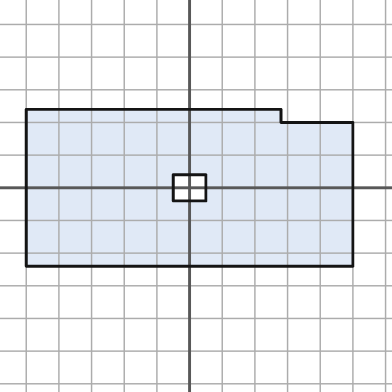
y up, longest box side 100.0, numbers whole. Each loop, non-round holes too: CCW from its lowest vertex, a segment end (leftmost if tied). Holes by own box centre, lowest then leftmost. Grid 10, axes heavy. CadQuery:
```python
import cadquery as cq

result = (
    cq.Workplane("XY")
    .moveTo(-50.0, -24.0)
    .lineTo(50.0, -24.0)
    .lineTo(50.0, 20.0)
    .lineTo(28.0, 20.0)
    .lineTo(28.0, 24.0)
    .lineTo(-50.0, 24.0)
    .close()
    .moveTo(-5.0, -4.0)
    .lineTo(5.0, -4.0)
    .lineTo(5.0, 4.0)
    .lineTo(-5.0, 4.0)
    .close()
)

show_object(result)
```